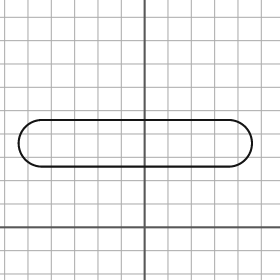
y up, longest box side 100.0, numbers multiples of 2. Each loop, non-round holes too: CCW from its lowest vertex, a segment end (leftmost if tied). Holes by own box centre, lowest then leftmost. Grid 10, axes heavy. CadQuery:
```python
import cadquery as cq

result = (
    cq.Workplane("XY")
    .moveTo(-44.0, 26.0)
    .lineTo(36.0, 26.0)
    .threePointArc((46.0, 36.0), (36.0, 46.0))
    .lineTo(-44.0, 46.0)
    .threePointArc((-54.0, 36.0), (-44.0, 26.0))
    .close()
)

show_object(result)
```